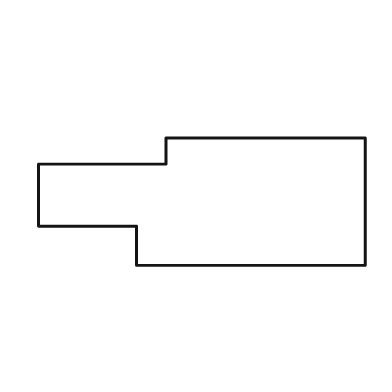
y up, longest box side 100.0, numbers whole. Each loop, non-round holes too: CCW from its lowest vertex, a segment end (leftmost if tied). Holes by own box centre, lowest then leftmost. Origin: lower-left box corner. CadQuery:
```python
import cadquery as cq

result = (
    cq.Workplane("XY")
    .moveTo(30.0, 0.0)
    .lineTo(100.0, 0.0)
    .lineTo(100.0, 39.0)
    .lineTo(39.0, 39.0)
    .lineTo(39.0, 31.0)
    .lineTo(0.0, 31.0)
    .lineTo(0.0, 12.0)
    .lineTo(30.0, 12.0)
    .close()
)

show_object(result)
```